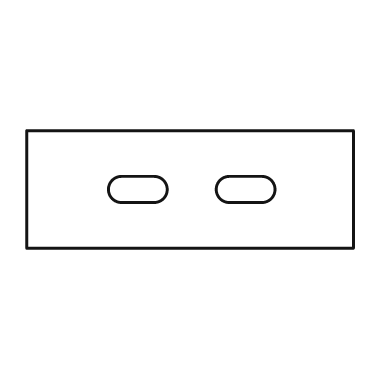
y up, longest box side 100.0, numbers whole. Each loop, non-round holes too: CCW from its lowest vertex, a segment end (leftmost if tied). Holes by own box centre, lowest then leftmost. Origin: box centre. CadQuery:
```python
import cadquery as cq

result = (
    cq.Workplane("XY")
    .moveTo(-50.0, -18.0)
    .lineTo(50.0, -18.0)
    .lineTo(50.0, 18.0)
    .lineTo(-50.0, 18.0)
    .close()
    .moveTo(-21.0, -4.0)
    .lineTo(-11.0, -4.0)
    .threePointArc((-7.0, 0.0), (-11.0, 4.0))
    .lineTo(-21.0, 4.0)
    .threePointArc((-25.0, 0.0), (-21.0, -4.0))
    .close()
    .moveTo(12.0, -4.0)
    .lineTo(22.0, -4.0)
    .threePointArc((26.0, 0.0), (22.0, 4.0))
    .lineTo(12.0, 4.0)
    .threePointArc((8.0, 0.0), (12.0, -4.0))
    .close()
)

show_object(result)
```